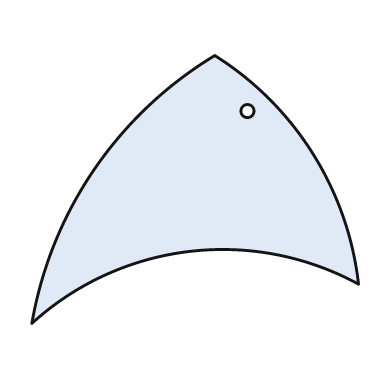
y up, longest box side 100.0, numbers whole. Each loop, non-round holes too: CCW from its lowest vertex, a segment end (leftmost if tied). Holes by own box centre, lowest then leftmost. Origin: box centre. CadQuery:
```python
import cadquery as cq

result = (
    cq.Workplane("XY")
    .moveTo(-50.0, -41.0)
    .threePointArc((-2.0, -19.0), (50.0, -29.0))
    .threePointArc((36.0, 11.0), (6.0, 41.0))
    .threePointArc((-31.0, 6.0), (-50.0, -41.0))
    .close()
    .moveTo(16.0, 24.0)
    .circle(2.0)
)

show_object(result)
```